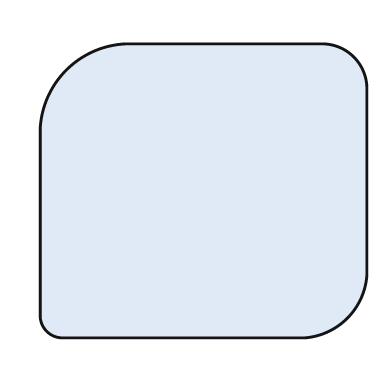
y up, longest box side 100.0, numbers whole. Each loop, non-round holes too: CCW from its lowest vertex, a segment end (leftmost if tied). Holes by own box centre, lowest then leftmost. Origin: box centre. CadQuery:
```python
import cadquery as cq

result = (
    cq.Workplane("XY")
    .moveTo(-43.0, -45.0)
    .lineTo(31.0, -45.0)
    .threePointArc((44.0, -39.0), (50.0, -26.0))
    .lineTo(50.0, 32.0)
    .threePointArc((46.0, 41.0), (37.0, 45.0))
    .lineTo(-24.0, 45.0)
    .threePointArc((-42.0, 37.0), (-50.0, 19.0))
    .lineTo(-50.0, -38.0)
    .threePointArc((-48.0, -43.0), (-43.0, -45.0))
    .close()
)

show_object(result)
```